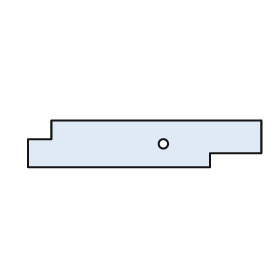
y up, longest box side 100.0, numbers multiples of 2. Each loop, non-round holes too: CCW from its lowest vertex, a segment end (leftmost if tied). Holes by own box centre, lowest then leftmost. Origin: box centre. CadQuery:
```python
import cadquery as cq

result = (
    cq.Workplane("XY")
    .moveTo(-50.0, -10.0)
    .lineTo(28.0, -10.0)
    .lineTo(28.0, -4.0)
    .lineTo(50.0, -4.0)
    .lineTo(50.0, 10.0)
    .lineTo(-40.0, 10.0)
    .lineTo(-40.0, 2.0)
    .lineTo(-50.0, 2.0)
    .close()
    .moveTo(8.0, 0.0)
    .circle(2.0)
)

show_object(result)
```